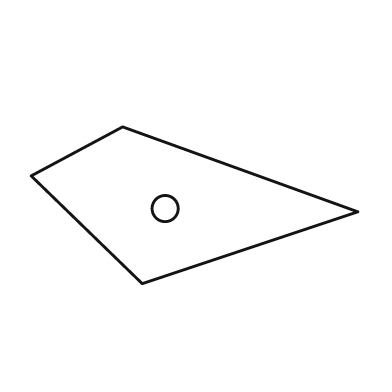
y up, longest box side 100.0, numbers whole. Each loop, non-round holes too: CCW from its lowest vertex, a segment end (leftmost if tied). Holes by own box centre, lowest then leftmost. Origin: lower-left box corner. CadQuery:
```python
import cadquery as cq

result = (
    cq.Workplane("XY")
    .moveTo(34.0, 0.0)
    .lineTo(100.0, 22.0)
    .lineTo(28.0, 48.0)
    .lineTo(0.0, 33.0)
    .close()
    .moveTo(41.0, 23.0)
    .circle(4.0)
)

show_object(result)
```